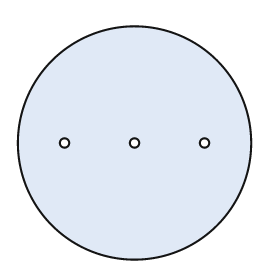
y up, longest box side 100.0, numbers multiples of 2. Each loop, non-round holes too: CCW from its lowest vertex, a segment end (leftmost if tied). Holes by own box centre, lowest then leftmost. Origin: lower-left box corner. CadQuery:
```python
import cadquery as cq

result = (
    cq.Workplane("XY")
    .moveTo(50.0, 50.0)
    .circle(50.0)
    .moveTo(20.0, 50.0)
    .circle(2.0)
    .moveTo(50.0, 50.0)
    .circle(2.0)
    .moveTo(80.0, 50.0)
    .circle(2.0)
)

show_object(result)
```